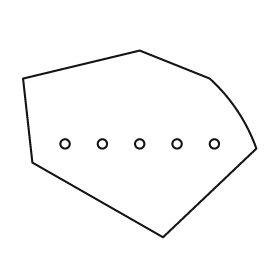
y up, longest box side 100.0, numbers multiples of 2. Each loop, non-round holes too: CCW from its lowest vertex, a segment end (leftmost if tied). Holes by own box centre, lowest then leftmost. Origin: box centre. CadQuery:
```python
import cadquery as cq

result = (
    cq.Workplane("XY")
    .moveTo(10.0, -40.0)
    .lineTo(50.0, -2.0)
    .threePointArc((42.0, 14.0), (30.0, 28.0))
    .lineTo(0.0, 40.0)
    .lineTo(-50.0, 28.0)
    .lineTo(-46.0, -8.0)
    .close()
    .moveTo(-32.0, 0.0)
    .circle(2.0)
    .moveTo(-16.0, 0.0)
    .circle(2.0)
    .moveTo(0.0, 0.0)
    .circle(2.0)
    .moveTo(16.0, 0.0)
    .circle(2.0)
    .moveTo(32.0, 0.0)
    .circle(2.0)
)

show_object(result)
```